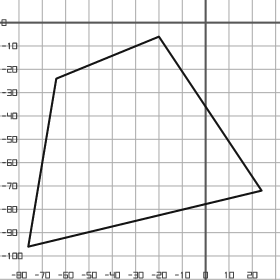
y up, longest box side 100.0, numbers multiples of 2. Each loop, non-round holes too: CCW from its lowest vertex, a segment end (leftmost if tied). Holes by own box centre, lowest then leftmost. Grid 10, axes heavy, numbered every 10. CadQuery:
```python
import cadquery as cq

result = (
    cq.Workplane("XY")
    .moveTo(-76.0, -96.0)
    .lineTo(24.0, -72.0)
    .lineTo(-20.0, -6.0)
    .lineTo(-64.0, -24.0)
    .close()
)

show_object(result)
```